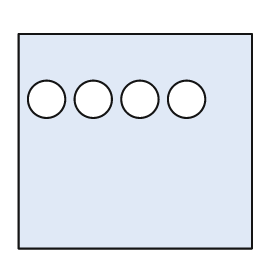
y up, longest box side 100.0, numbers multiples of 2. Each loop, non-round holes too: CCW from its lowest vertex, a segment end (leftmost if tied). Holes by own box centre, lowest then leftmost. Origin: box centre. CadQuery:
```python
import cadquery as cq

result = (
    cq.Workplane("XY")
    .moveTo(-50.0, -46.0)
    .lineTo(50.0, -46.0)
    .lineTo(50.0, 46.0)
    .lineTo(-50.0, 46.0)
    .close()
    .moveTo(-38.0, 18.0)
    .circle(8.0)
    .moveTo(-18.0, 18.0)
    .circle(8.0)
    .moveTo(2.0, 18.0)
    .circle(8.0)
    .moveTo(22.0, 18.0)
    .circle(8.0)
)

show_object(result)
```